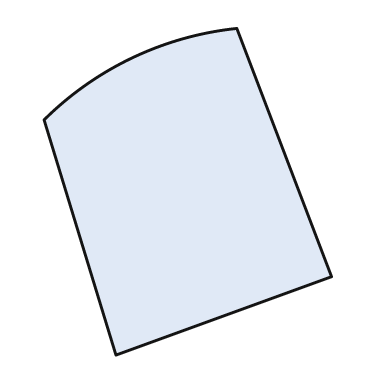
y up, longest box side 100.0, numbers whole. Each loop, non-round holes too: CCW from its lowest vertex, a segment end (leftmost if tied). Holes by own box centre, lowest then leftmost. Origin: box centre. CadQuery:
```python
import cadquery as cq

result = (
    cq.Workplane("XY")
    .moveTo(-22.0, -50.0)
    .lineTo(44.0, -26.0)
    .lineTo(15.0, 50.0)
    .threePointArc((-17.0, 41.0), (-44.0, 22.0))
    .close()
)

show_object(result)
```